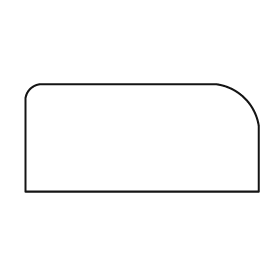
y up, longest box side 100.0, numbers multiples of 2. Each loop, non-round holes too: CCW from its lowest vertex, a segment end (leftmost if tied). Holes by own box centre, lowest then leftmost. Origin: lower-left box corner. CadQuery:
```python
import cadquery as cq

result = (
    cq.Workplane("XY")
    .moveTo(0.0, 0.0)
    .lineTo(100.0, 0.0)
    .lineTo(100.0, 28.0)
    .threePointArc((94.0, 40.0), (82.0, 46.0))
    .lineTo(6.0, 46.0)
    .threePointArc((2.0, 44.0), (0.0, 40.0))
    .close()
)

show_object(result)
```